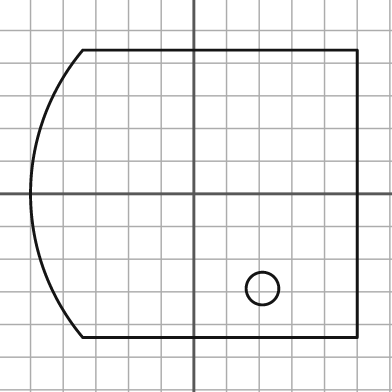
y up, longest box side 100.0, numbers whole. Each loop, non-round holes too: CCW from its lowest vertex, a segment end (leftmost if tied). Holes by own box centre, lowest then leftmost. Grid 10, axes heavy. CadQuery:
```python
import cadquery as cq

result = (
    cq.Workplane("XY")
    .moveTo(-34.0, -44.0)
    .lineTo(50.0, -44.0)
    .lineTo(50.0, 44.0)
    .lineTo(-34.0, 44.0)
    .threePointArc((-50.0, 0.0), (-34.0, -44.0))
    .close()
    .moveTo(21.0, -29.0)
    .circle(5.0)
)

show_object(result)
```